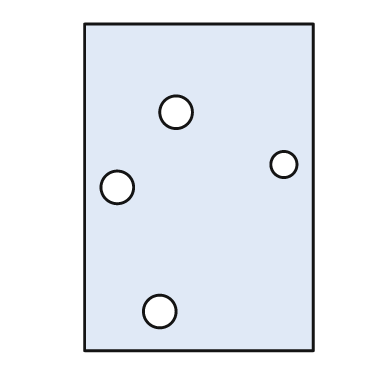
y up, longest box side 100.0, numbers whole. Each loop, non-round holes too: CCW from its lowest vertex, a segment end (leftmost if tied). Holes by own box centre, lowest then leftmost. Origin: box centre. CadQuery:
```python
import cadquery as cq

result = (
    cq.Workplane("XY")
    .moveTo(-35.0, -50.0)
    .lineTo(35.0, -50.0)
    .lineTo(35.0, 50.0)
    .lineTo(-35.0, 50.0)
    .close()
    .moveTo(-12.0, -38.0)
    .circle(5.0)
    .moveTo(-25.0, 0.0)
    .circle(5.0)
    .moveTo(26.0, 7.0)
    .circle(4.0)
    .moveTo(-7.0, 23.0)
    .circle(5.0)
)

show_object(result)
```